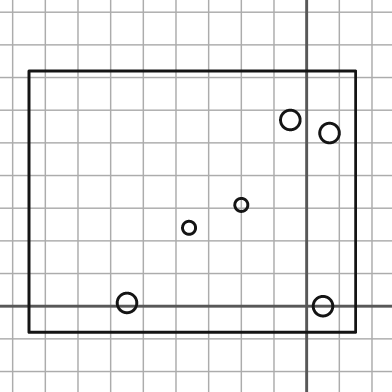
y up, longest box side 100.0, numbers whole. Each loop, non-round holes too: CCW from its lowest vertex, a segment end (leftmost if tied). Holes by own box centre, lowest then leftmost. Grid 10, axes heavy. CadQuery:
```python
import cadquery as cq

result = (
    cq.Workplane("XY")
    .moveTo(-85.0, -8.0)
    .lineTo(15.0, -8.0)
    .lineTo(15.0, 72.0)
    .lineTo(-85.0, 72.0)
    .close()
    .moveTo(5.0, 0.0)
    .circle(3.0)
    .moveTo(-55.0, 1.0)
    .circle(3.0)
    .moveTo(-36.0, 24.0)
    .circle(2.0)
    .moveTo(-20.0, 31.0)
    .circle(2.0)
    .moveTo(7.0, 53.0)
    .circle(3.0)
    .moveTo(-5.0, 57.0)
    .circle(3.0)
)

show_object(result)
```